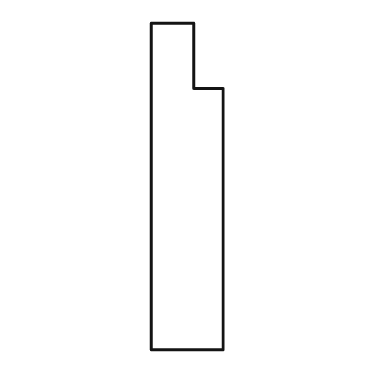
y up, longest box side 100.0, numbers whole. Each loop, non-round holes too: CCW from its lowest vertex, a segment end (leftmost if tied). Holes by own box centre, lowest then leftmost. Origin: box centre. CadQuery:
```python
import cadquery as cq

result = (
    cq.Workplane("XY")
    .moveTo(-11.0, -50.0)
    .lineTo(11.0, -50.0)
    .lineTo(11.0, 30.0)
    .lineTo(2.0, 30.0)
    .lineTo(2.0, 50.0)
    .lineTo(-11.0, 50.0)
    .close()
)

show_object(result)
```